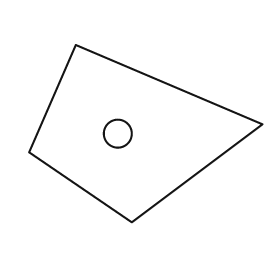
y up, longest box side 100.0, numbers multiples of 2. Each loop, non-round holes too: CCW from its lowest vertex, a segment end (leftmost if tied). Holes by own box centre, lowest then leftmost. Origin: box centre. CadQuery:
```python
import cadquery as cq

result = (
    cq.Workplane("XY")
    .moveTo(-6.0, -38.0)
    .lineTo(50.0, 4.0)
    .lineTo(-30.0, 38.0)
    .lineTo(-50.0, -8.0)
    .close()
    .moveTo(-12.0, 0.0)
    .circle(6.0)
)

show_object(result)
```